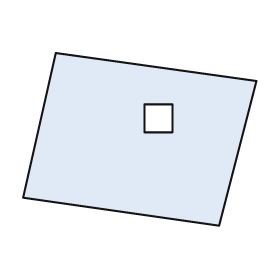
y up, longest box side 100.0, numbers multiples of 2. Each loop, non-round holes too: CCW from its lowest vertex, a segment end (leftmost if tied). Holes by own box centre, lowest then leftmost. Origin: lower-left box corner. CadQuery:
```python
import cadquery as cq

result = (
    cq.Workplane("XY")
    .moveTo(84.0, 0.0)
    .lineTo(100.0, 62.0)
    .lineTo(14.0, 74.0)
    .lineTo(0.0, 12.0)
    .close()
    .moveTo(52.0, 40.0)
    .lineTo(64.0, 40.0)
    .lineTo(64.0, 52.0)
    .lineTo(52.0, 52.0)
    .close()
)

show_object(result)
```